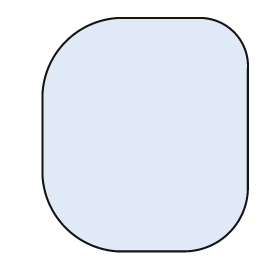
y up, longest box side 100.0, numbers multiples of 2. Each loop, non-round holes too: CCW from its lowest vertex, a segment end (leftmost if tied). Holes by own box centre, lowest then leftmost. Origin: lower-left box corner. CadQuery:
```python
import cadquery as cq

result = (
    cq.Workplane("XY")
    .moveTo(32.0, 0.0)
    .lineTo(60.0, 0.0)
    .threePointArc((80.0, 8.0), (88.0, 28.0))
    .lineTo(88.0, 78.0)
    .threePointArc((82.0, 94.0), (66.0, 100.0))
    .lineTo(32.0, 100.0)
    .threePointArc((10.0, 90.0), (0.0, 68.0))
    .lineTo(0.0, 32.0)
    .threePointArc((10.0, 10.0), (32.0, 0.0))
    .close()
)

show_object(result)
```